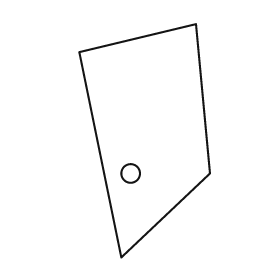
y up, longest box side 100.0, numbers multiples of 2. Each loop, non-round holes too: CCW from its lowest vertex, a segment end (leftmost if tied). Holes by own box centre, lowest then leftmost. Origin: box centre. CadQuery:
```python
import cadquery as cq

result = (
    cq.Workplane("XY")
    .moveTo(-10.0, -50.0)
    .lineTo(28.0, -14.0)
    .lineTo(22.0, 50.0)
    .lineTo(-28.0, 38.0)
    .close()
    .moveTo(-6.0, -14.0)
    .circle(4.0)
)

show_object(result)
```